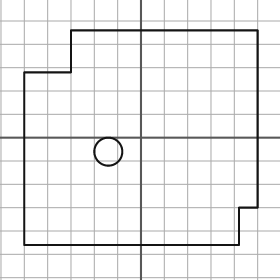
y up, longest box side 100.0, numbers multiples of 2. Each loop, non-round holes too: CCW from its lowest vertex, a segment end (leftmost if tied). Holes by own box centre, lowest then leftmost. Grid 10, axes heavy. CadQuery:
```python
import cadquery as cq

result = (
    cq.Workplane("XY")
    .moveTo(-50.0, -46.0)
    .lineTo(42.0, -46.0)
    .lineTo(42.0, -30.0)
    .lineTo(50.0, -30.0)
    .lineTo(50.0, 46.0)
    .lineTo(-30.0, 46.0)
    .lineTo(-30.0, 28.0)
    .lineTo(-50.0, 28.0)
    .close()
    .moveTo(-14.0, -6.0)
    .circle(6.0)
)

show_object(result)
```